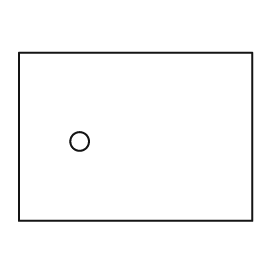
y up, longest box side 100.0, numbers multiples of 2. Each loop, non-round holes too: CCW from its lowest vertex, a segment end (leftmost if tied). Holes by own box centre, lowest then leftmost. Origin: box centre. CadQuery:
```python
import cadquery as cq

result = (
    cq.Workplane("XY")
    .moveTo(-50.0, -36.0)
    .lineTo(50.0, -36.0)
    .lineTo(50.0, 36.0)
    .lineTo(-50.0, 36.0)
    .close()
    .moveTo(-24.0, -2.0)
    .circle(4.0)
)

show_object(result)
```